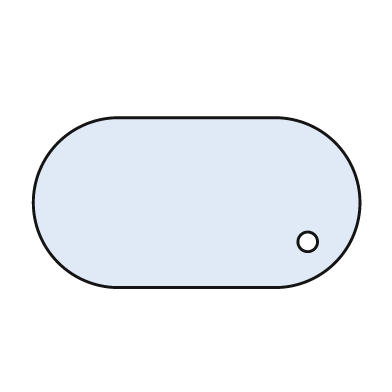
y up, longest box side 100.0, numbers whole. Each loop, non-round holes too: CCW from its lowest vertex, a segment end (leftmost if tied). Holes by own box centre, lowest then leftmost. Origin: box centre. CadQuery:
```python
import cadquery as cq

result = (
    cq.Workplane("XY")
    .moveTo(-24.0, -26.0)
    .lineTo(24.0, -26.0)
    .threePointArc((50.0, 0.0), (24.0, 26.0))
    .lineTo(-24.0, 26.0)
    .threePointArc((-50.0, 0.0), (-24.0, -26.0))
    .close()
    .moveTo(34.0, -12.0)
    .circle(3.0)
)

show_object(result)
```